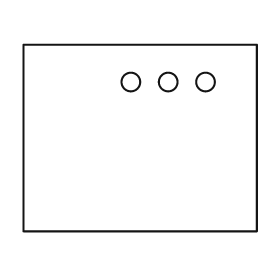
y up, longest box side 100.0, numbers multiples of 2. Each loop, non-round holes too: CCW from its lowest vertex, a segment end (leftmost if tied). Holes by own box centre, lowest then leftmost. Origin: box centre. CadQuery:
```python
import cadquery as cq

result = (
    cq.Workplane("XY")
    .moveTo(-50.0, -40.0)
    .lineTo(50.0, -40.0)
    .lineTo(50.0, 40.0)
    .lineTo(-50.0, 40.0)
    .close()
    .moveTo(-4.0, 24.0)
    .circle(4.0)
    .moveTo(12.0, 24.0)
    .circle(4.0)
    .moveTo(28.0, 24.0)
    .circle(4.0)
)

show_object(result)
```